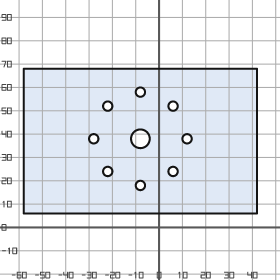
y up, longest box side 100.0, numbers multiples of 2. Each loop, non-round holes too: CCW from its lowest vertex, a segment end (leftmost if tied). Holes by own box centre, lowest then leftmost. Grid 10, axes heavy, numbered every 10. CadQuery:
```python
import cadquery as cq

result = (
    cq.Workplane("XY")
    .moveTo(-58.0, 6.0)
    .lineTo(42.0, 6.0)
    .lineTo(42.0, 68.0)
    .lineTo(-58.0, 68.0)
    .close()
    .moveTo(-8.0, 18.0)
    .circle(2.0)
    .moveTo(-22.0, 24.0)
    .circle(2.0)
    .moveTo(6.0, 24.0)
    .circle(2.0)
    .moveTo(-28.0, 38.0)
    .circle(2.0)
    .moveTo(-8.0, 38.0)
    .circle(4.0)
    .moveTo(12.0, 38.0)
    .circle(2.0)
    .moveTo(-22.0, 52.0)
    .circle(2.0)
    .moveTo(6.0, 52.0)
    .circle(2.0)
    .moveTo(-8.0, 58.0)
    .circle(2.0)
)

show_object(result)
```